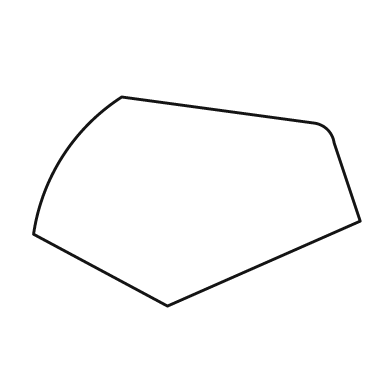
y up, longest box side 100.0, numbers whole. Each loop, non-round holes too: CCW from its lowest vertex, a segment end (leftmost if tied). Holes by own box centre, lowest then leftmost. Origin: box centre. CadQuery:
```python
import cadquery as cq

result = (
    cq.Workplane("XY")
    .moveTo(-9.0, -32.0)
    .lineTo(50.0, -6.0)
    .lineTo(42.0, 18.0)
    .threePointArc((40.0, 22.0), (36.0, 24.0))
    .lineTo(-23.0, 32.0)
    .threePointArc((-41.0, 14.0), (-50.0, -10.0))
    .close()
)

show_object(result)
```